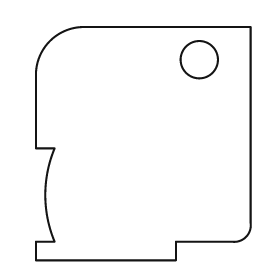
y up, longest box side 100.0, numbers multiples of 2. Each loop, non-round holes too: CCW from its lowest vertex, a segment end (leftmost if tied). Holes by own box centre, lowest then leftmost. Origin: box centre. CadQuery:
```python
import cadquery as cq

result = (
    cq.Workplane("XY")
    .moveTo(-46.0, -50.0)
    .lineTo(14.0, -50.0)
    .lineTo(14.0, -42.0)
    .lineTo(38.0, -42.0)
    .threePointArc((44.0, -40.0), (46.0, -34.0))
    .lineTo(46.0, 50.0)
    .lineTo(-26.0, 50.0)
    .threePointArc((-40.0, 44.0), (-46.0, 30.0))
    .lineTo(-46.0, -2.0)
    .lineTo(-38.0, -2.0)
    .threePointArc((-42.0, -22.0), (-38.0, -42.0))
    .lineTo(-46.0, -42.0)
    .close()
    .moveTo(24.0, 36.0)
    .circle(8.0)
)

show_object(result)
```